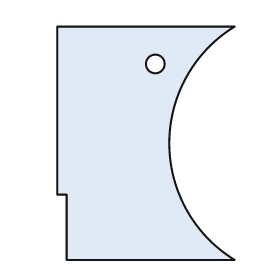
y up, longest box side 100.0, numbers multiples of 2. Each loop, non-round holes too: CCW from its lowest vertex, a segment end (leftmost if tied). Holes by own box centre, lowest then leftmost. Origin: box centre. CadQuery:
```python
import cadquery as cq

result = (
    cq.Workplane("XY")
    .moveTo(-34.0, -50.0)
    .lineTo(38.0, -50.0)
    .threePointArc((10.0, 0.0), (38.0, 50.0))
    .lineTo(-38.0, 50.0)
    .lineTo(-38.0, -22.0)
    .lineTo(-34.0, -22.0)
    .close()
    .moveTo(4.0, 34.0)
    .circle(4.0)
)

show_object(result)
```